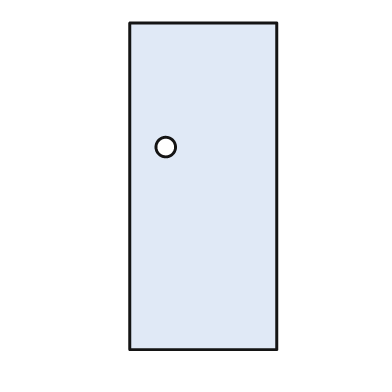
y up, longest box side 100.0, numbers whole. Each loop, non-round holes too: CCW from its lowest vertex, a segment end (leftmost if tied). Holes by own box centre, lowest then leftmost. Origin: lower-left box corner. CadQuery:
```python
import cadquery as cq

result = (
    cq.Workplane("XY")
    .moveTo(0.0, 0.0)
    .lineTo(45.0, 0.0)
    .lineTo(45.0, 100.0)
    .lineTo(0.0, 100.0)
    .close()
    .moveTo(11.0, 62.0)
    .circle(3.0)
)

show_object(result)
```